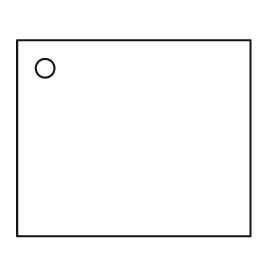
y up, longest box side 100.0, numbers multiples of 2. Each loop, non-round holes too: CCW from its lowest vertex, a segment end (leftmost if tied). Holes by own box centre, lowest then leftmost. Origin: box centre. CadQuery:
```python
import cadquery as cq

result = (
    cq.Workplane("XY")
    .moveTo(-50.0, -42.0)
    .lineTo(50.0, -42.0)
    .lineTo(50.0, 42.0)
    .lineTo(-50.0, 42.0)
    .close()
    .moveTo(-38.0, 30.0)
    .circle(4.0)
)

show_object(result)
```